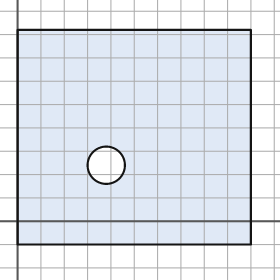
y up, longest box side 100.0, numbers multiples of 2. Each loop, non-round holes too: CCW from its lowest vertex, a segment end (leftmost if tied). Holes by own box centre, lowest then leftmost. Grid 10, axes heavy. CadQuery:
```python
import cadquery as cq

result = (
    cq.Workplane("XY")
    .moveTo(0.0, -10.0)
    .lineTo(100.0, -10.0)
    .lineTo(100.0, 82.0)
    .lineTo(0.0, 82.0)
    .close()
    .moveTo(38.0, 24.0)
    .circle(8.0)
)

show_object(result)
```